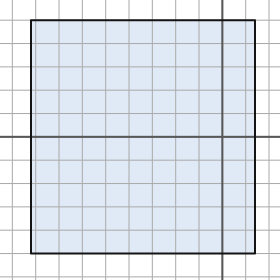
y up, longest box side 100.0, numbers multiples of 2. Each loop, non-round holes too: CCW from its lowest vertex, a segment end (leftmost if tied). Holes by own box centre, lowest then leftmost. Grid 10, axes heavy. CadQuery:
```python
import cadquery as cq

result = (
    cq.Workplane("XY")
    .moveTo(-82.0, -50.0)
    .lineTo(14.0, -50.0)
    .lineTo(14.0, 50.0)
    .lineTo(-82.0, 50.0)
    .close()
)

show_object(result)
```